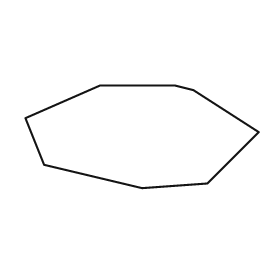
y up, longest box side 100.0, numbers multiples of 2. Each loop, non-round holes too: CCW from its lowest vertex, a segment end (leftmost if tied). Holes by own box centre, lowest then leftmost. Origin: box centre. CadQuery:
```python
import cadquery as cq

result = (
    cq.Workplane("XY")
    .moveTo(0.0, -22.0)
    .lineTo(28.0, -20.0)
    .lineTo(50.0, 2.0)
    .lineTo(22.0, 20.0)
    .lineTo(14.0, 22.0)
    .lineTo(-18.0, 22.0)
    .lineTo(-50.0, 8.0)
    .lineTo(-42.0, -12.0)
    .close()
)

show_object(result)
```